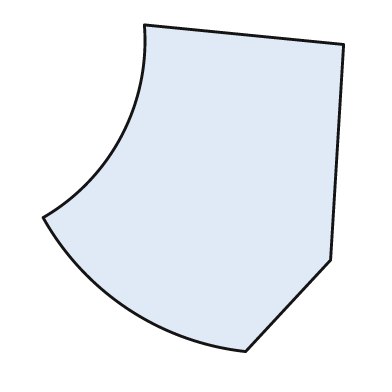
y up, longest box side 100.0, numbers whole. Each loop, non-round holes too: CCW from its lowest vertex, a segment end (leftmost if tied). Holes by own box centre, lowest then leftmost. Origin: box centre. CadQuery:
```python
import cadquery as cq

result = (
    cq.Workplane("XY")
    .moveTo(16.0, -50.0)
    .lineTo(42.0, -22.0)
    .lineTo(46.0, 44.0)
    .lineTo(-15.0, 50.0)
    .threePointArc((-22.0, 16.0), (-46.0, -9.0))
    .threePointArc((-20.0, -37.0), (16.0, -50.0))
    .close()
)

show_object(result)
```